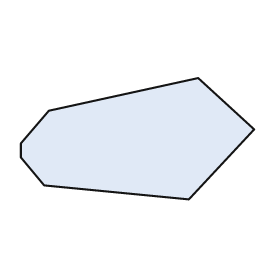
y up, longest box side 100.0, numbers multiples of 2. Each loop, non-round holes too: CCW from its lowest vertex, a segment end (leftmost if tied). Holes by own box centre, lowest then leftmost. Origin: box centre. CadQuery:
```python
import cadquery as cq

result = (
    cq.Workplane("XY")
    .moveTo(22.0, -26.0)
    .lineTo(50.0, 4.0)
    .lineTo(26.0, 26.0)
    .lineTo(-38.0, 12.0)
    .lineTo(-50.0, -2.0)
    .lineTo(-50.0, -8.0)
    .lineTo(-40.0, -20.0)
    .close()
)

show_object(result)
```